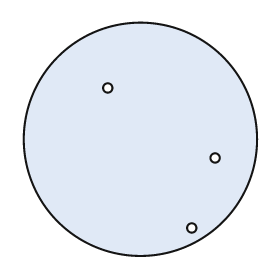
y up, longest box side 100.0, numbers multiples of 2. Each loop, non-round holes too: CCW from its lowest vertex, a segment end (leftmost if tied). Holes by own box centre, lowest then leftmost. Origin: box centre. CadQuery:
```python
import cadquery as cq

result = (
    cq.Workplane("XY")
    .moveTo(0.0, 0.0)
    .circle(50.0)
    .moveTo(22.0, -38.0)
    .circle(2.0)
    .moveTo(32.0, -8.0)
    .circle(2.0)
    .moveTo(-14.0, 22.0)
    .circle(2.0)
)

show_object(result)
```